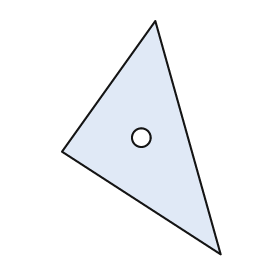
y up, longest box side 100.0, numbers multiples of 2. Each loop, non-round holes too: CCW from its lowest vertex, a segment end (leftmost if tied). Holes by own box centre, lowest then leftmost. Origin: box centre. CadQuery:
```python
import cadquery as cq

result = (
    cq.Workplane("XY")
    .moveTo(34.0, -50.0)
    .lineTo(6.0, 50.0)
    .lineTo(-34.0, -6.0)
    .close()
    .moveTo(0.0, 0.0)
    .circle(4.0)
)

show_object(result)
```